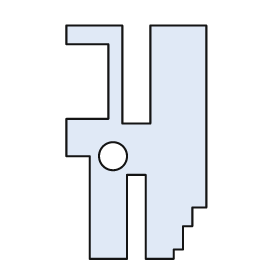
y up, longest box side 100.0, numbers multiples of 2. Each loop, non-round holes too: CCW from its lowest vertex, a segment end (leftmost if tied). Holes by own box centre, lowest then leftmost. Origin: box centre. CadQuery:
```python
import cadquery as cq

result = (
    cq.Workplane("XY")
    .moveTo(-20.0, -50.0)
    .lineTo(-4.0, -50.0)
    .lineTo(-4.0, -14.0)
    .lineTo(4.0, -14.0)
    .lineTo(4.0, -50.0)
    .lineTo(16.0, -50.0)
    .lineTo(16.0, -46.0)
    .lineTo(20.0, -46.0)
    .lineTo(20.0, -36.0)
    .lineTo(24.0, -36.0)
    .lineTo(24.0, -28.0)
    .lineTo(30.0, -28.0)
    .lineTo(30.0, 50.0)
    .lineTo(6.0, 50.0)
    .lineTo(6.0, 8.0)
    .lineTo(-6.0, 8.0)
    .lineTo(-6.0, 50.0)
    .lineTo(-30.0, 50.0)
    .lineTo(-30.0, 42.0)
    .lineTo(-12.0, 42.0)
    .lineTo(-12.0, 10.0)
    .lineTo(-30.0, 10.0)
    .lineTo(-30.0, -6.0)
    .lineTo(-20.0, -6.0)
    .close()
    .moveTo(-10.0, -6.0)
    .circle(6.0)
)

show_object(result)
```